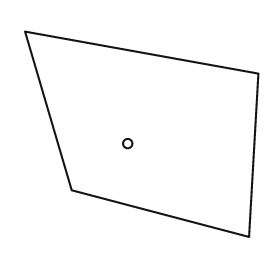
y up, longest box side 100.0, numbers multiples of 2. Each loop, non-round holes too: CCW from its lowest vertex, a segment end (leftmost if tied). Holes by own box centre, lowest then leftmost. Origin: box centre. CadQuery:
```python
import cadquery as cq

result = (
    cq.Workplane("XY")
    .moveTo(46.0, -44.0)
    .lineTo(50.0, 26.0)
    .lineTo(-50.0, 44.0)
    .lineTo(-30.0, -24.0)
    .close()
    .moveTo(-6.0, -4.0)
    .circle(2.0)
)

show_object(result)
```